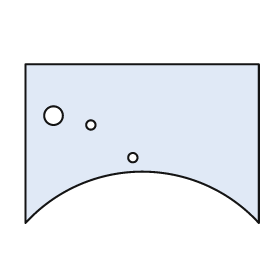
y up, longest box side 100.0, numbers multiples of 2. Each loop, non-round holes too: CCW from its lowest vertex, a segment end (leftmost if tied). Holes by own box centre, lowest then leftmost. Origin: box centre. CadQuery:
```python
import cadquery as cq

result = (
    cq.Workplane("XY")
    .moveTo(-50.0, -34.0)
    .threePointArc((0.0, -12.0), (50.0, -34.0))
    .lineTo(50.0, 34.0)
    .lineTo(-50.0, 34.0)
    .close()
    .moveTo(-4.0, -6.0)
    .circle(2.0)
    .moveTo(-22.0, 8.0)
    .circle(2.0)
    .moveTo(-38.0, 12.0)
    .circle(4.0)
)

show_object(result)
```